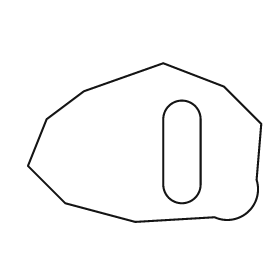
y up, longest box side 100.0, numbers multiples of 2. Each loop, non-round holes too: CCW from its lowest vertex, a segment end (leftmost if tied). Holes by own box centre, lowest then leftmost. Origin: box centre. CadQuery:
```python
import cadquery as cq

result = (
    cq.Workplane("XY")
    .moveTo(-4.0, -34.0)
    .lineTo(30.0, -32.0)
    .threePointArc((44.0, -30.0), (48.0, -16.0))
    .lineTo(50.0, 8.0)
    .lineTo(34.0, 24.0)
    .lineTo(8.0, 34.0)
    .lineTo(-26.0, 22.0)
    .lineTo(-42.0, 10.0)
    .lineTo(-50.0, -10.0)
    .lineTo(-34.0, -26.0)
    .close()
    .moveTo(8.0, -18.0)
    .threePointArc((16.0, -26.0), (24.0, -18.0))
    .lineTo(24.0, 10.0)
    .threePointArc((16.0, 18.0), (8.0, 10.0))
    .close()
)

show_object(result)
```